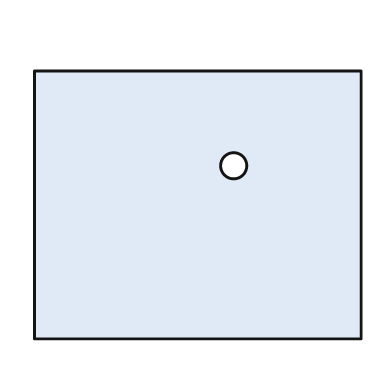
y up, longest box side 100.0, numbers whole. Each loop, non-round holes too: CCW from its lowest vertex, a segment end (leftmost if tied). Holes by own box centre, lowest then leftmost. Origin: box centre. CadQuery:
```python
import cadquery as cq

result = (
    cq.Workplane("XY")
    .moveTo(-50.0, -41.0)
    .lineTo(50.0, -41.0)
    .lineTo(50.0, 41.0)
    .lineTo(-50.0, 41.0)
    .close()
    .moveTo(11.0, 12.0)
    .circle(4.0)
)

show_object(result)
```